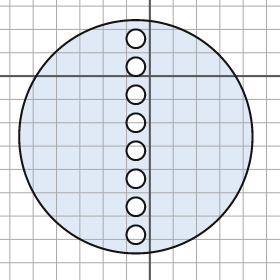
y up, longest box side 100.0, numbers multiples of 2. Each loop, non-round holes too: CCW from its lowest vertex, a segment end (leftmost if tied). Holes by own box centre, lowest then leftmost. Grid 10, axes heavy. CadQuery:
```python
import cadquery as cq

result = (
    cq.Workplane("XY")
    .moveTo(-6.0, -26.0)
    .circle(50.0)
    .moveTo(-6.0, -68.0)
    .circle(4.0)
    .moveTo(-6.0, -56.0)
    .circle(4.0)
    .moveTo(-6.0, -44.0)
    .circle(4.0)
    .moveTo(-6.0, -32.0)
    .circle(4.0)
    .moveTo(-6.0, -20.0)
    .circle(4.0)
    .moveTo(-6.0, -8.0)
    .circle(4.0)
    .moveTo(-6.0, 4.0)
    .circle(4.0)
    .moveTo(-6.0, 16.0)
    .circle(4.0)
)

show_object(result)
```